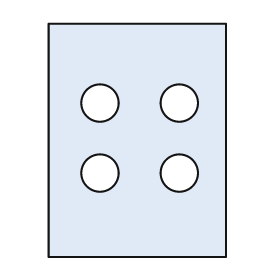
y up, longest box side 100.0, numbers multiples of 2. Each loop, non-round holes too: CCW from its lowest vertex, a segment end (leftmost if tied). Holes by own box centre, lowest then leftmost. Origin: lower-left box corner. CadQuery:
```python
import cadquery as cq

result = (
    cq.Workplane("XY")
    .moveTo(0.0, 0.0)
    .lineTo(76.0, 0.0)
    .lineTo(76.0, 100.0)
    .lineTo(0.0, 100.0)
    .close()
    .moveTo(22.0, 36.0)
    .circle(8.0)
    .moveTo(56.0, 36.0)
    .circle(8.0)
    .moveTo(22.0, 66.0)
    .circle(8.0)
    .moveTo(56.0, 66.0)
    .circle(8.0)
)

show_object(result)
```